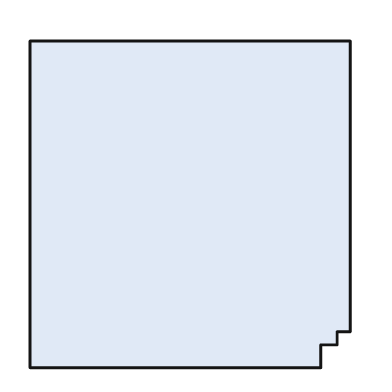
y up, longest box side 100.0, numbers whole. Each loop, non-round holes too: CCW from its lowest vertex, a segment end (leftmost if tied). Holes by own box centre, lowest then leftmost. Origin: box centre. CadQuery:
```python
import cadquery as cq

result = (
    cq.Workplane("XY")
    .moveTo(-49.0, -50.0)
    .lineTo(40.0, -50.0)
    .lineTo(40.0, -43.0)
    .lineTo(45.0, -43.0)
    .lineTo(45.0, -39.0)
    .lineTo(49.0, -39.0)
    .lineTo(49.0, 50.0)
    .lineTo(-49.0, 50.0)
    .close()
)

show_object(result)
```